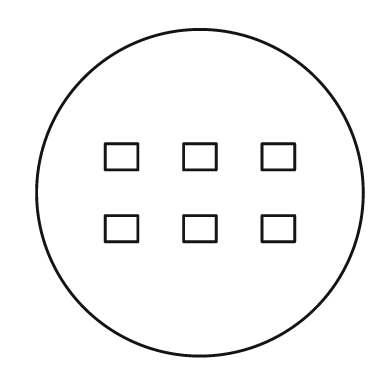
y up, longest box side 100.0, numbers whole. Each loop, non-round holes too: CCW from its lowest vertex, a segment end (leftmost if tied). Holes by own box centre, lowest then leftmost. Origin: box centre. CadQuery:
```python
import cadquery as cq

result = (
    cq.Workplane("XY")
    .moveTo(0.0, 0.0)
    .circle(50.0)
    .moveTo(-29.0, -15.0)
    .lineTo(-19.0, -15.0)
    .lineTo(-19.0, -7.0)
    .lineTo(-29.0, -7.0)
    .close()
    .moveTo(-5.0, -15.0)
    .lineTo(5.0, -15.0)
    .lineTo(5.0, -7.0)
    .lineTo(-5.0, -7.0)
    .close()
    .moveTo(19.0, -15.0)
    .lineTo(29.0, -15.0)
    .lineTo(29.0, -7.0)
    .lineTo(19.0, -7.0)
    .close()
    .moveTo(-29.0, 7.0)
    .lineTo(-19.0, 7.0)
    .lineTo(-19.0, 15.0)
    .lineTo(-29.0, 15.0)
    .close()
    .moveTo(-5.0, 7.0)
    .lineTo(5.0, 7.0)
    .lineTo(5.0, 15.0)
    .lineTo(-5.0, 15.0)
    .close()
    .moveTo(19.0, 7.0)
    .lineTo(29.0, 7.0)
    .lineTo(29.0, 15.0)
    .lineTo(19.0, 15.0)
    .close()
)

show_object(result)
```